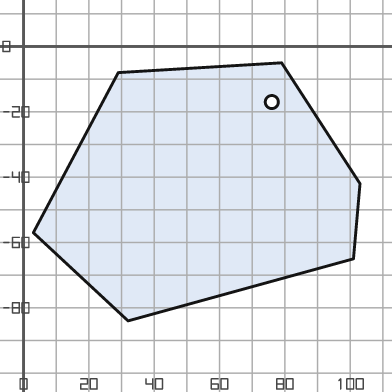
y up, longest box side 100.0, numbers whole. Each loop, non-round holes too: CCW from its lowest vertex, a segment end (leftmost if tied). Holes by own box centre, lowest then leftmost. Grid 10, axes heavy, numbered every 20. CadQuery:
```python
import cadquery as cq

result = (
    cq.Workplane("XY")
    .moveTo(32.0, -84.0)
    .lineTo(101.0, -65.0)
    .lineTo(103.0, -42.0)
    .lineTo(79.0, -5.0)
    .lineTo(29.0, -8.0)
    .lineTo(3.0, -57.0)
    .close()
    .moveTo(76.0, -17.0)
    .circle(2.0)
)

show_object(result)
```